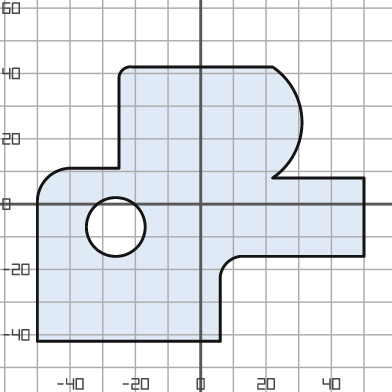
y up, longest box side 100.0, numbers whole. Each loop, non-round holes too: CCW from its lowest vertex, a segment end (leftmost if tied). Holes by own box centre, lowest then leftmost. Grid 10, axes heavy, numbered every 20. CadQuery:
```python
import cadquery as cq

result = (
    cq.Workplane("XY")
    .moveTo(-50.0, -42.0)
    .lineTo(6.0, -42.0)
    .lineTo(6.0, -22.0)
    .threePointArc((8.0, -18.0), (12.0, -16.0))
    .lineTo(50.0, -16.0)
    .lineTo(50.0, 8.0)
    .lineTo(22.0, 8.0)
    .threePointArc((31.0, 25.0), (22.0, 42.0))
    .lineTo(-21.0, 42.0)
    .threePointArc((-24.0, 41.0), (-25.0, 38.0))
    .lineTo(-25.0, 11.0)
    .lineTo(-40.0, 11.0)
    .threePointArc((-47.0, 8.0), (-50.0, 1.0))
    .close()
    .moveTo(-26.0, -7.0)
    .circle(9.0)
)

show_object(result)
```